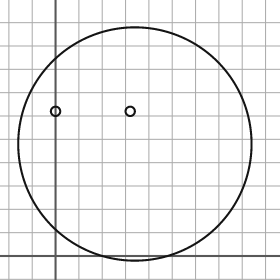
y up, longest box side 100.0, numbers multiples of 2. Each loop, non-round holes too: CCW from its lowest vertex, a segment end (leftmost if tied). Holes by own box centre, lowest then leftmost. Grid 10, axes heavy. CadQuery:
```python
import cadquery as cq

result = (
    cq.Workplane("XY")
    .moveTo(34.0, 48.0)
    .circle(50.0)
    .moveTo(0.0, 62.0)
    .circle(2.0)
    .moveTo(32.0, 62.0)
    .circle(2.0)
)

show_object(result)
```